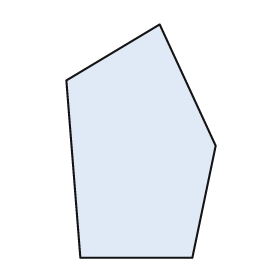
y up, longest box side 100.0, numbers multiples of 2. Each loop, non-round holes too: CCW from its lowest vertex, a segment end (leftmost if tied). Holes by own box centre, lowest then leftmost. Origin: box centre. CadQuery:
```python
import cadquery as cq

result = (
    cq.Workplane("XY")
    .moveTo(-26.0, -50.0)
    .lineTo(22.0, -50.0)
    .lineTo(32.0, -2.0)
    .lineTo(8.0, 50.0)
    .lineTo(-32.0, 26.0)
    .close()
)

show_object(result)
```